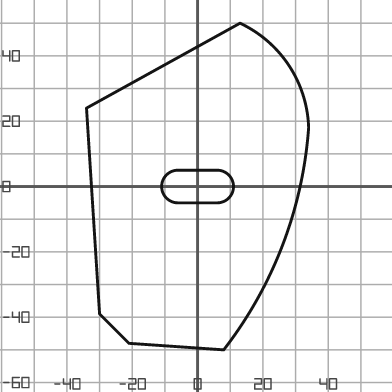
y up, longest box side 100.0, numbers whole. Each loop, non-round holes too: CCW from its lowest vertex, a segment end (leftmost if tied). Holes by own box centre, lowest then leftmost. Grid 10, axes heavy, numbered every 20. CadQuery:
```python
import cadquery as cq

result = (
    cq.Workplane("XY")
    .moveTo(8.0, -50.0)
    .threePointArc((26.0, -18.0), (34.0, 18.0))
    .threePointArc((28.0, 37.0), (13.0, 50.0))
    .lineTo(-34.0, 24.0)
    .lineTo(-30.0, -39.0)
    .lineTo(-21.0, -48.0)
    .close()
    .moveTo(-6.0, -5.0)
    .lineTo(6.0, -5.0)
    .threePointArc((11.0, 0.0), (6.0, 5.0))
    .lineTo(-6.0, 5.0)
    .threePointArc((-11.0, 0.0), (-6.0, -5.0))
    .close()
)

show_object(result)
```